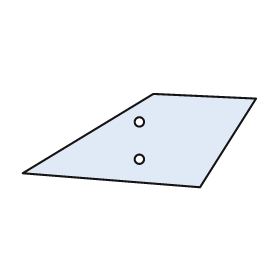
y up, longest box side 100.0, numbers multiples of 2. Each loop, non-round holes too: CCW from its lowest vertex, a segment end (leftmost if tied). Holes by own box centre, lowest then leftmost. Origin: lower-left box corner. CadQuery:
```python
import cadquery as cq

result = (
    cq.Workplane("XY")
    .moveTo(76.0, 0.0)
    .lineTo(100.0, 38.0)
    .lineTo(56.0, 40.0)
    .lineTo(0.0, 6.0)
    .close()
    .moveTo(50.0, 12.0)
    .circle(2.0)
    .moveTo(50.0, 28.0)
    .circle(2.0)
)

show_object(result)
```